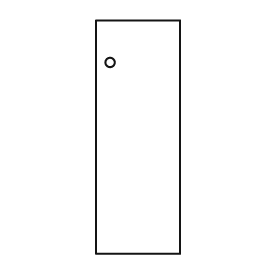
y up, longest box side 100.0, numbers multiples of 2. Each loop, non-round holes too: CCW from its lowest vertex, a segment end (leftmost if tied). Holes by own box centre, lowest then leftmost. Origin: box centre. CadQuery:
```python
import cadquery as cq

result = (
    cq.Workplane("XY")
    .moveTo(-18.0, -50.0)
    .lineTo(18.0, -50.0)
    .lineTo(18.0, 50.0)
    .lineTo(-18.0, 50.0)
    .close()
    .moveTo(-12.0, 32.0)
    .circle(2.0)
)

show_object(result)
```